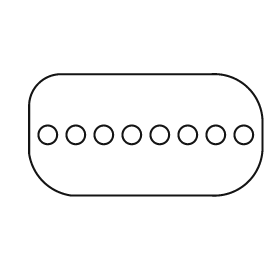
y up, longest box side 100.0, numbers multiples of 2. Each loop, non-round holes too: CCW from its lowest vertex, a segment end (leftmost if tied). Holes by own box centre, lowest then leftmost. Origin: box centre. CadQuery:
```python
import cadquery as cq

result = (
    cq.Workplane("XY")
    .moveTo(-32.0, -26.0)
    .lineTo(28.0, -26.0)
    .threePointArc((44.0, -20.0), (50.0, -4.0))
    .lineTo(50.0, 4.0)
    .threePointArc((44.0, 20.0), (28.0, 26.0))
    .lineTo(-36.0, 26.0)
    .threePointArc((-46.0, 22.0), (-50.0, 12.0))
    .lineTo(-50.0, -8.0)
    .threePointArc((-44.0, -20.0), (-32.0, -26.0))
    .close()
    .moveTo(-42.0, 0.0)
    .circle(4.0)
    .moveTo(-30.0, 0.0)
    .circle(4.0)
    .moveTo(-18.0, 0.0)
    .circle(4.0)
    .moveTo(-6.0, 0.0)
    .circle(4.0)
    .moveTo(6.0, 0.0)
    .circle(4.0)
    .moveTo(18.0, 0.0)
    .circle(4.0)
    .moveTo(30.0, 0.0)
    .circle(4.0)
    .moveTo(42.0, 0.0)
    .circle(4.0)
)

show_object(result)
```